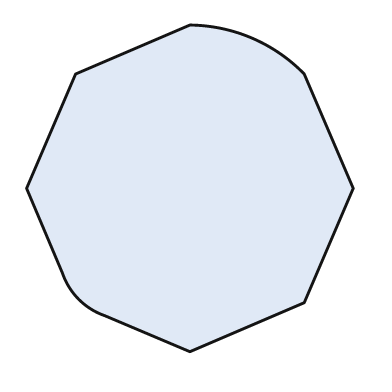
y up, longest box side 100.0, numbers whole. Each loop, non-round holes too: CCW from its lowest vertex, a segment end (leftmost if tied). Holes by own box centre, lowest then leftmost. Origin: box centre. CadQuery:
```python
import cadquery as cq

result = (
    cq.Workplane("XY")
    .moveTo(0.0, -50.0)
    .lineTo(35.0, -35.0)
    .lineTo(50.0, 0.0)
    .lineTo(35.0, 35.0)
    .threePointArc((19.0, 46.0), (0.0, 50.0))
    .lineTo(-35.0, 35.0)
    .lineTo(-50.0, 0.0)
    .lineTo(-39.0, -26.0)
    .threePointArc((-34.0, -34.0), (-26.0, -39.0))
    .close()
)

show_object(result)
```